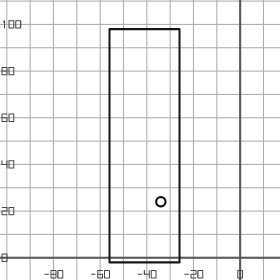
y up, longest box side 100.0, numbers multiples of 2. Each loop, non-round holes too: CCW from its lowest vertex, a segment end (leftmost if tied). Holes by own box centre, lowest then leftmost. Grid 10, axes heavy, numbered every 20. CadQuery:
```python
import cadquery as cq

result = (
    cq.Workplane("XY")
    .moveTo(-56.0, -2.0)
    .lineTo(-26.0, -2.0)
    .lineTo(-26.0, 98.0)
    .lineTo(-56.0, 98.0)
    .close()
    .moveTo(-34.0, 24.0)
    .circle(2.0)
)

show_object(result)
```